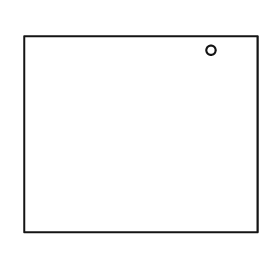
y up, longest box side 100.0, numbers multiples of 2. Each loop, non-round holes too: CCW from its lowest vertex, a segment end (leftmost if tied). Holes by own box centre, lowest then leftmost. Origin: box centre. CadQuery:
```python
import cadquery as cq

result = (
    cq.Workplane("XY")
    .moveTo(-50.0, -42.0)
    .lineTo(50.0, -42.0)
    .lineTo(50.0, 42.0)
    .lineTo(-50.0, 42.0)
    .close()
    .moveTo(30.0, 36.0)
    .circle(2.0)
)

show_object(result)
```